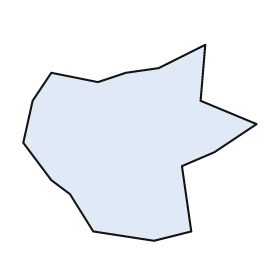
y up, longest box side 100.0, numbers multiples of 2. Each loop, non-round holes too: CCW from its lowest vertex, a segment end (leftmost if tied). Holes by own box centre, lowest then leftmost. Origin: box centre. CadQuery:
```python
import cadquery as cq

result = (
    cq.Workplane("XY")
    .moveTo(6.0, -42.0)
    .lineTo(22.0, -38.0)
    .lineTo(18.0, -10.0)
    .lineTo(32.0, -4.0)
    .lineTo(50.0, 8.0)
    .lineTo(26.0, 18.0)
    .lineTo(28.0, 42.0)
    .lineTo(8.0, 32.0)
    .lineTo(-6.0, 30.0)
    .lineTo(-18.0, 26.0)
    .lineTo(-38.0, 30.0)
    .lineTo(-46.0, 18.0)
    .lineTo(-50.0, 0.0)
    .lineTo(-38.0, -16.0)
    .lineTo(-30.0, -22.0)
    .lineTo(-20.0, -38.0)
    .close()
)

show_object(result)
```